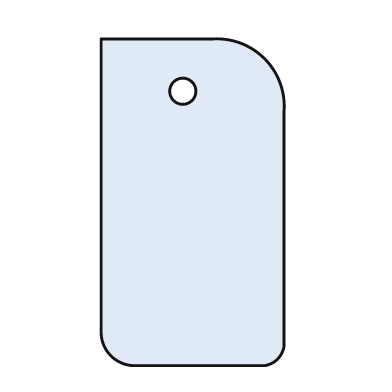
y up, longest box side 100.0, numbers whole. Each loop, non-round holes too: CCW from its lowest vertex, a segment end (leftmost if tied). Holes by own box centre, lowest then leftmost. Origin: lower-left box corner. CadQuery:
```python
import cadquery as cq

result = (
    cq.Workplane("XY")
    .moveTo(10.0, 0.0)
    .lineTo(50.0, 0.0)
    .threePointArc((54.0, 2.0), (56.0, 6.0))
    .lineTo(56.0, 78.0)
    .threePointArc((50.0, 94.0), (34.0, 100.0))
    .lineTo(0.0, 100.0)
    .lineTo(0.0, 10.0)
    .threePointArc((3.0, 3.0), (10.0, 0.0))
    .close()
    .moveTo(25.0, 84.0)
    .circle(4.0)
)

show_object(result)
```